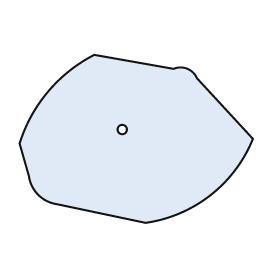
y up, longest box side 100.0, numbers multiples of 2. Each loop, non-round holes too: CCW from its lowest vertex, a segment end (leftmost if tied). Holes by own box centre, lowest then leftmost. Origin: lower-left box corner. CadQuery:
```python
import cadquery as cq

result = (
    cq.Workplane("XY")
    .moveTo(54.0, 0.0)
    .threePointArc((82.0, 12.0), (100.0, 36.0))
    .lineTo(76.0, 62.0)
    .threePointArc((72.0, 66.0), (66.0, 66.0))
    .lineTo(32.0, 72.0)
    .threePointArc((12.0, 56.0), (0.0, 34.0))
    .lineTo(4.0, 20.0)
    .threePointArc((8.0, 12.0), (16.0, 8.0))
    .close()
    .moveTo(44.0, 40.0)
    .circle(2.0)
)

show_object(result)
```